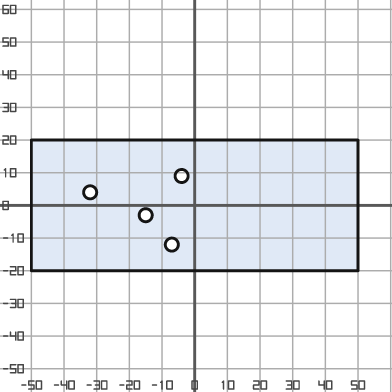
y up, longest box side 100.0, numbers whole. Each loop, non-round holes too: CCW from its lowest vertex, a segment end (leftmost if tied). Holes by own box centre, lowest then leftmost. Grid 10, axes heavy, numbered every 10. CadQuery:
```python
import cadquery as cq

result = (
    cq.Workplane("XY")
    .moveTo(-50.0, -20.0)
    .lineTo(50.0, -20.0)
    .lineTo(50.0, 20.0)
    .lineTo(-50.0, 20.0)
    .close()
    .moveTo(-7.0, -12.0)
    .circle(2.0)
    .moveTo(-15.0, -3.0)
    .circle(2.0)
    .moveTo(-32.0, 4.0)
    .circle(2.0)
    .moveTo(-4.0, 9.0)
    .circle(2.0)
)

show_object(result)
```